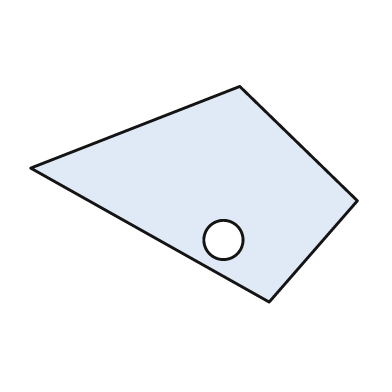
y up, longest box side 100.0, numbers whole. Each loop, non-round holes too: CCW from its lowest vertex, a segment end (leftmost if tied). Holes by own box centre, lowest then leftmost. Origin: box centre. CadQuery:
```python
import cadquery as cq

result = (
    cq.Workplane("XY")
    .moveTo(23.0, -33.0)
    .lineTo(50.0, -2.0)
    .lineTo(14.0, 33.0)
    .lineTo(-50.0, 8.0)
    .close()
    .moveTo(9.0, -14.0)
    .circle(6.0)
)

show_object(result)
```